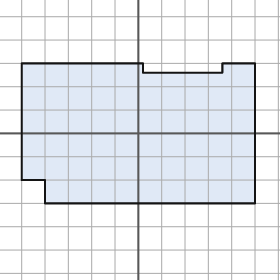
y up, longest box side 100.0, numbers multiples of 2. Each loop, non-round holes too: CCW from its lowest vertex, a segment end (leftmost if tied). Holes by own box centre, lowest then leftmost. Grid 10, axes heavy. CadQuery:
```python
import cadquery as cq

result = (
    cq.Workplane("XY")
    .moveTo(-40.0, -30.0)
    .lineTo(50.0, -30.0)
    .lineTo(50.0, 30.0)
    .lineTo(36.0, 30.0)
    .lineTo(36.0, 26.0)
    .lineTo(2.0, 26.0)
    .lineTo(2.0, 30.0)
    .lineTo(-50.0, 30.0)
    .lineTo(-50.0, -20.0)
    .lineTo(-40.0, -20.0)
    .close()
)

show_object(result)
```